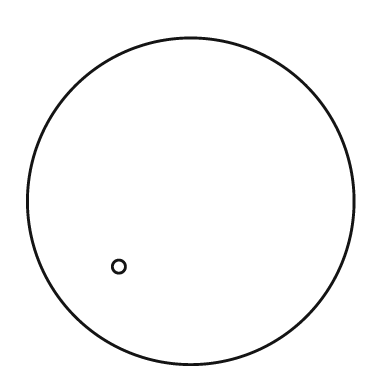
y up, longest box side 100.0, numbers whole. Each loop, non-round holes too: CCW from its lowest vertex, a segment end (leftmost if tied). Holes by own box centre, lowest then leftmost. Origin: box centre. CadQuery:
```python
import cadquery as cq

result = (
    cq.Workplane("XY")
    .moveTo(0.0, 0.0)
    .circle(50.0)
    .moveTo(-22.0, -20.0)
    .circle(2.0)
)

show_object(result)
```